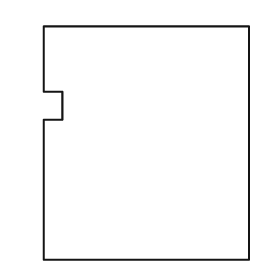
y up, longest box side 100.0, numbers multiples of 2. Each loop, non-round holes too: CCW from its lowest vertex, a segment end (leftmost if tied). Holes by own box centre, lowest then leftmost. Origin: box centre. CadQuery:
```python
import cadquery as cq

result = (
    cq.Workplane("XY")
    .moveTo(-44.0, -50.0)
    .lineTo(44.0, -50.0)
    .lineTo(44.0, 50.0)
    .lineTo(-44.0, 50.0)
    .lineTo(-44.0, 22.0)
    .lineTo(-36.0, 22.0)
    .lineTo(-36.0, 10.0)
    .lineTo(-44.0, 10.0)
    .close()
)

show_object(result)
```